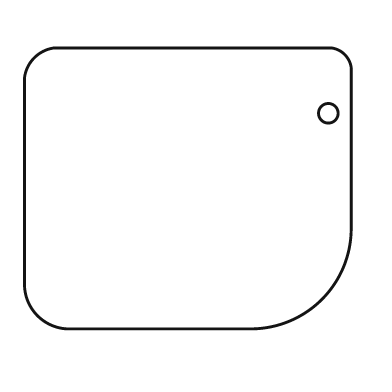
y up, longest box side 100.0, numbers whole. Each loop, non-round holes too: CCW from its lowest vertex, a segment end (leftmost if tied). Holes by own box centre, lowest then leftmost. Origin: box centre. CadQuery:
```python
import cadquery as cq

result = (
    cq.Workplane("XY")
    .moveTo(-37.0, -43.0)
    .lineTo(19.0, -43.0)
    .threePointArc((41.0, -34.0), (50.0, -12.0))
    .lineTo(50.0, 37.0)
    .threePointArc((48.0, 41.0), (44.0, 43.0))
    .lineTo(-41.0, 43.0)
    .threePointArc((-47.0, 40.0), (-50.0, 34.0))
    .lineTo(-50.0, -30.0)
    .threePointArc((-46.0, -39.0), (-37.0, -43.0))
    .close()
    .moveTo(43.0, 23.0)
    .circle(3.0)
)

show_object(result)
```